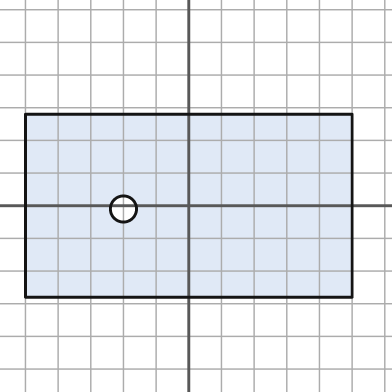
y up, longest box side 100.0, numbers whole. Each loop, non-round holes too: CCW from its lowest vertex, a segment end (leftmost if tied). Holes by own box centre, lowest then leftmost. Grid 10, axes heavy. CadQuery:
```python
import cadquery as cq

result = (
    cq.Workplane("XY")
    .moveTo(-50.0, -28.0)
    .lineTo(50.0, -28.0)
    .lineTo(50.0, 28.0)
    .lineTo(-50.0, 28.0)
    .close()
    .moveTo(-20.0, -1.0)
    .circle(4.0)
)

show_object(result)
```